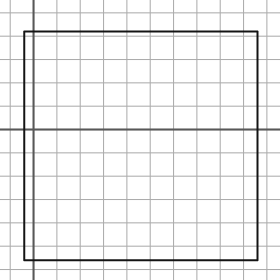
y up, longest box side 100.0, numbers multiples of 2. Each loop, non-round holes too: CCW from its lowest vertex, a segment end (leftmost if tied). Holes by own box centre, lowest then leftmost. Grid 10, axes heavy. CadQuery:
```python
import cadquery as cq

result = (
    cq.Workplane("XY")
    .moveTo(-4.0, -56.0)
    .lineTo(96.0, -56.0)
    .lineTo(96.0, 42.0)
    .lineTo(-4.0, 42.0)
    .close()
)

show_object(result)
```